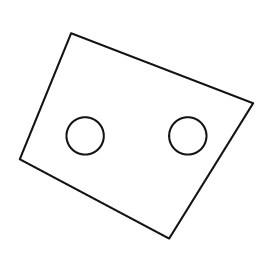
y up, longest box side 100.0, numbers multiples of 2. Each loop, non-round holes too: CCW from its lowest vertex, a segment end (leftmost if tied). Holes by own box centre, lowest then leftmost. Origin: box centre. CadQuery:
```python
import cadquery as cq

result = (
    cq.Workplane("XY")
    .moveTo(14.0, -44.0)
    .lineTo(50.0, 14.0)
    .lineTo(-28.0, 44.0)
    .lineTo(-50.0, -10.0)
    .close()
    .moveTo(-22.0, 0.0)
    .circle(8.0)
    .moveTo(22.0, 0.0)
    .circle(8.0)
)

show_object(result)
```